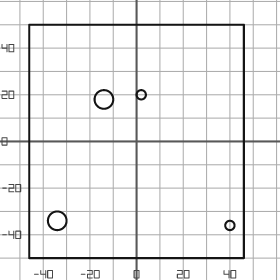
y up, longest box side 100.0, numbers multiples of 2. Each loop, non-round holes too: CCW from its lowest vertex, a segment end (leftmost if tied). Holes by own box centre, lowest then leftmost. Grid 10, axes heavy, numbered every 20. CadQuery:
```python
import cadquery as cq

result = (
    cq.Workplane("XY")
    .moveTo(-46.0, -50.0)
    .lineTo(46.0, -50.0)
    .lineTo(46.0, 50.0)
    .lineTo(-46.0, 50.0)
    .close()
    .moveTo(40.0, -36.0)
    .circle(2.0)
    .moveTo(-34.0, -34.0)
    .circle(4.0)
    .moveTo(-14.0, 18.0)
    .circle(4.0)
    .moveTo(2.0, 20.0)
    .circle(2.0)
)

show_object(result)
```